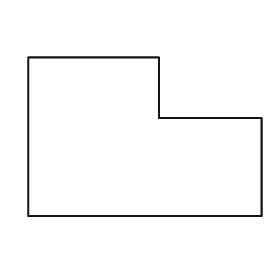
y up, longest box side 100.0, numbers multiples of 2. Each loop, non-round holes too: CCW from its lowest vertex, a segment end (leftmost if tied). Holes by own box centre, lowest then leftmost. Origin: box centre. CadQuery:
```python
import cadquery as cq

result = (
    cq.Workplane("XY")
    .moveTo(-50.0, -34.0)
    .lineTo(50.0, -34.0)
    .lineTo(50.0, 8.0)
    .lineTo(6.0, 8.0)
    .lineTo(6.0, 34.0)
    .lineTo(-50.0, 34.0)
    .close()
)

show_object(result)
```